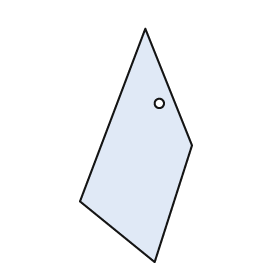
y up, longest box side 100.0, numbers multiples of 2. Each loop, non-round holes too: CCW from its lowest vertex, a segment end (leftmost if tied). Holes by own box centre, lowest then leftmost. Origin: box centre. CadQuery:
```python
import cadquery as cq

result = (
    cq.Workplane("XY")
    .moveTo(8.0, -50.0)
    .lineTo(24.0, 0.0)
    .lineTo(4.0, 50.0)
    .lineTo(-24.0, -24.0)
    .close()
    .moveTo(10.0, 18.0)
    .circle(2.0)
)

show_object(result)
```